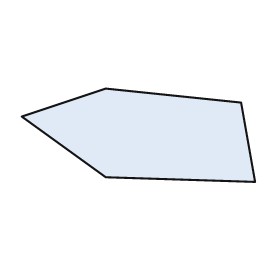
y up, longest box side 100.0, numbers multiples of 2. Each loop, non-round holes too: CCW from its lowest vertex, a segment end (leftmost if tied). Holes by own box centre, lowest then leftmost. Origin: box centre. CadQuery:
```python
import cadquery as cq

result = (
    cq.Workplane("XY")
    .moveTo(50.0, -20.0)
    .lineTo(44.0, 14.0)
    .lineTo(-14.0, 20.0)
    .lineTo(-50.0, 8.0)
    .lineTo(-14.0, -18.0)
    .close()
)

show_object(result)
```